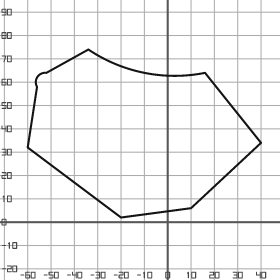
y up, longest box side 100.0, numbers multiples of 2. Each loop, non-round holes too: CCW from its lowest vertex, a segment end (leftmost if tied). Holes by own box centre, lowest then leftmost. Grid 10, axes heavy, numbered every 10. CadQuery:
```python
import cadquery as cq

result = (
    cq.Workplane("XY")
    .moveTo(-20.0, 2.0)
    .lineTo(10.0, 6.0)
    .lineTo(40.0, 34.0)
    .lineTo(16.0, 64.0)
    .threePointArc((-10.0, 64.0), (-34.0, 74.0))
    .lineTo(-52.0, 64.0)
    .threePointArc((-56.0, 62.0), (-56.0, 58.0))
    .lineTo(-60.0, 32.0)
    .close()
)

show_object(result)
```